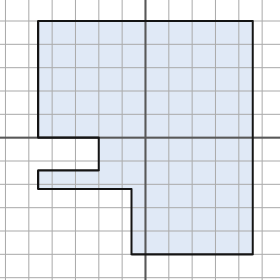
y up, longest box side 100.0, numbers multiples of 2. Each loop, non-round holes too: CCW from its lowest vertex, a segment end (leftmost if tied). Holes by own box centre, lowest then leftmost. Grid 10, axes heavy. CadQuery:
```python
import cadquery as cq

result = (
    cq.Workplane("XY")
    .moveTo(-6.0, -50.0)
    .lineTo(46.0, -50.0)
    .lineTo(46.0, 50.0)
    .lineTo(-46.0, 50.0)
    .lineTo(-46.0, 0.0)
    .lineTo(-20.0, 0.0)
    .lineTo(-20.0, -14.0)
    .lineTo(-46.0, -14.0)
    .lineTo(-46.0, -22.0)
    .lineTo(-6.0, -22.0)
    .close()
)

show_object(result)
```